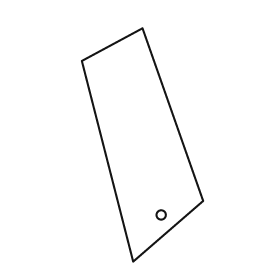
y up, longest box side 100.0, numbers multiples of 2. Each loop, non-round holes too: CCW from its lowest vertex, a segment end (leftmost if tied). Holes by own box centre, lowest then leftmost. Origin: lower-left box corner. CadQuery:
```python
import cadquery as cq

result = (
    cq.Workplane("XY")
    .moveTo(22.0, 0.0)
    .lineTo(52.0, 26.0)
    .lineTo(26.0, 100.0)
    .lineTo(0.0, 86.0)
    .close()
    .moveTo(34.0, 20.0)
    .circle(2.0)
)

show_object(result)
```